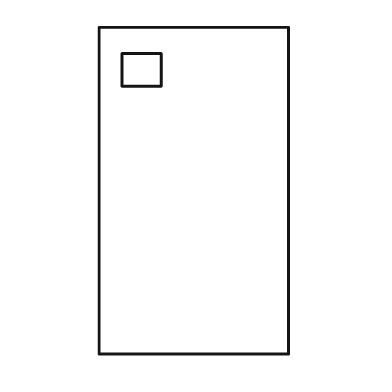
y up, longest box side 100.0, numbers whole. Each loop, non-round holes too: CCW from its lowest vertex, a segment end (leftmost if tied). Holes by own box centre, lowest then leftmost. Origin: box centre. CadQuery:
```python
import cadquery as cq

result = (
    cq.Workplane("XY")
    .moveTo(-29.0, -50.0)
    .lineTo(29.0, -50.0)
    .lineTo(29.0, 50.0)
    .lineTo(-29.0, 50.0)
    .close()
    .moveTo(-22.0, 32.0)
    .lineTo(-10.0, 32.0)
    .lineTo(-10.0, 42.0)
    .lineTo(-22.0, 42.0)
    .close()
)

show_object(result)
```